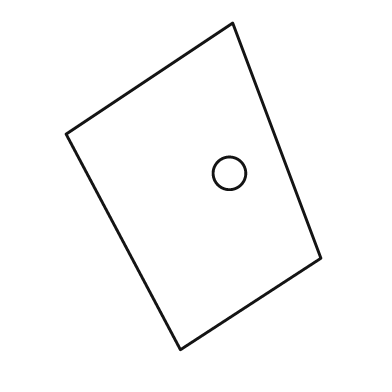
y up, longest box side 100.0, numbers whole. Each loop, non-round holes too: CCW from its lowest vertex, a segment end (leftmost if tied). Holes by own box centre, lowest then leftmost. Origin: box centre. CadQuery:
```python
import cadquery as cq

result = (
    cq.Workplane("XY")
    .moveTo(-4.0, -50.0)
    .lineTo(39.0, -22.0)
    .lineTo(12.0, 50.0)
    .lineTo(-39.0, 16.0)
    .close()
    .moveTo(11.0, 4.0)
    .circle(5.0)
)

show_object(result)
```